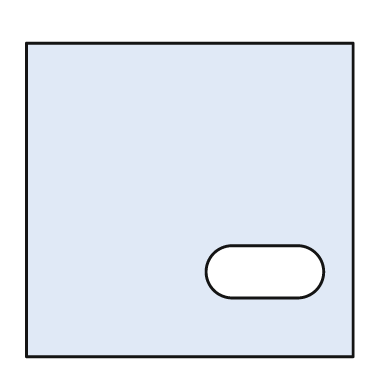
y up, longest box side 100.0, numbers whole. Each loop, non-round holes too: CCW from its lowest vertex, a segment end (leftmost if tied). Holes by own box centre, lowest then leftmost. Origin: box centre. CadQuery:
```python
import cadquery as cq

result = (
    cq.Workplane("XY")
    .moveTo(-50.0, -48.0)
    .lineTo(50.0, -48.0)
    .lineTo(50.0, 48.0)
    .lineTo(-50.0, 48.0)
    .close()
    .moveTo(13.0, -30.0)
    .lineTo(33.0, -30.0)
    .threePointArc((41.0, -22.0), (33.0, -14.0))
    .lineTo(13.0, -14.0)
    .threePointArc((5.0, -22.0), (13.0, -30.0))
    .close()
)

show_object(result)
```